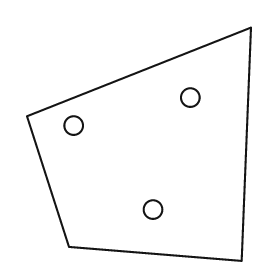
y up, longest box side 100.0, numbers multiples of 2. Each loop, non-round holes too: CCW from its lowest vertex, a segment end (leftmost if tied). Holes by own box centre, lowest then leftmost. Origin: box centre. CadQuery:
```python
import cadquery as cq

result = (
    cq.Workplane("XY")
    .moveTo(44.0, -50.0)
    .lineTo(48.0, 50.0)
    .lineTo(-48.0, 12.0)
    .lineTo(-30.0, -44.0)
    .close()
    .moveTo(6.0, -28.0)
    .circle(4.0)
    .moveTo(-28.0, 8.0)
    .circle(4.0)
    .moveTo(22.0, 20.0)
    .circle(4.0)
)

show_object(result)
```